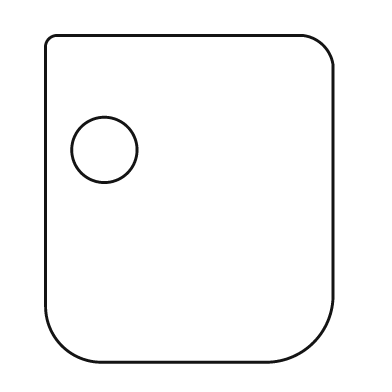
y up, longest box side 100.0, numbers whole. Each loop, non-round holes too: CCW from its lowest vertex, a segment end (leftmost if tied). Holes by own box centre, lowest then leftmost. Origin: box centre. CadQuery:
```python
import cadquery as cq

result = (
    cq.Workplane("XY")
    .moveTo(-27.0, -50.0)
    .lineTo(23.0, -50.0)
    .threePointArc((38.0, -44.0), (44.0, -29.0))
    .lineTo(44.0, 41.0)
    .threePointArc((41.0, 47.0), (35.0, 50.0))
    .lineTo(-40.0, 50.0)
    .threePointArc((-43.0, 49.0), (-44.0, 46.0))
    .lineTo(-44.0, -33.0)
    .threePointArc((-39.0, -45.0), (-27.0, -50.0))
    .close()
    .moveTo(-26.0, 15.0)
    .circle(10.0)
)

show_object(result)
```